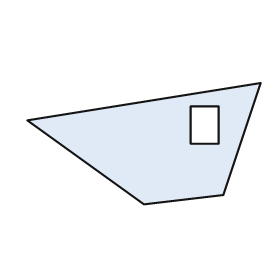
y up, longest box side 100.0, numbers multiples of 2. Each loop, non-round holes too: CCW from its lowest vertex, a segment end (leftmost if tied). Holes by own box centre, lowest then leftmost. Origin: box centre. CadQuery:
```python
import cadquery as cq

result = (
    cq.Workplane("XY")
    .moveTo(0.0, -26.0)
    .lineTo(34.0, -22.0)
    .lineTo(50.0, 26.0)
    .lineTo(-50.0, 10.0)
    .close()
    .moveTo(20.0, 0.0)
    .lineTo(32.0, 0.0)
    .lineTo(32.0, 16.0)
    .lineTo(20.0, 16.0)
    .close()
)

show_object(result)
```